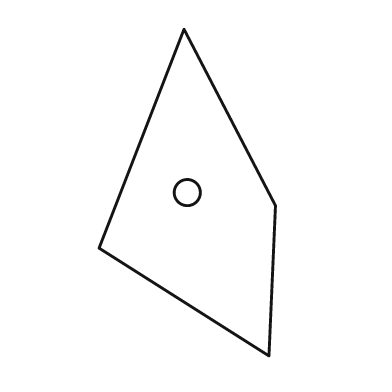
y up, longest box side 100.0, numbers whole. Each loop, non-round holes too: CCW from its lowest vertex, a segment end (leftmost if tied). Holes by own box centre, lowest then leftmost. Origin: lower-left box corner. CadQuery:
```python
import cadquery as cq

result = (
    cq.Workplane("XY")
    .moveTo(52.0, 0.0)
    .lineTo(54.0, 46.0)
    .lineTo(26.0, 100.0)
    .lineTo(0.0, 33.0)
    .close()
    .moveTo(27.0, 50.0)
    .circle(4.0)
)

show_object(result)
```